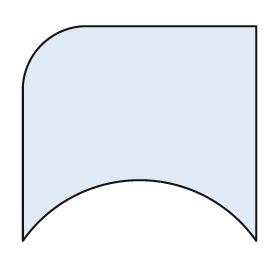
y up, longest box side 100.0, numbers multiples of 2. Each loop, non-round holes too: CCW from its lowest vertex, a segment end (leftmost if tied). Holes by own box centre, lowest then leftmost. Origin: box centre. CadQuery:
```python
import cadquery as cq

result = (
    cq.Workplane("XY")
    .moveTo(-50.0, -46.0)
    .threePointArc((0.0, -20.0), (50.0, -46.0))
    .lineTo(50.0, 46.0)
    .lineTo(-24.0, 46.0)
    .threePointArc((-42.0, 38.0), (-50.0, 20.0))
    .close()
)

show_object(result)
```